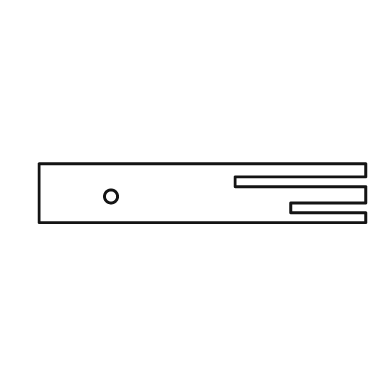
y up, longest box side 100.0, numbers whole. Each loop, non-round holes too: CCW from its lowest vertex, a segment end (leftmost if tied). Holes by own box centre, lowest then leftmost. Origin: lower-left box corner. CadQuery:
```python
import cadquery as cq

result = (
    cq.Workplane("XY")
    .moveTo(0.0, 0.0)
    .lineTo(100.0, 0.0)
    .lineTo(100.0, 3.0)
    .lineTo(77.0, 3.0)
    .lineTo(77.0, 6.0)
    .lineTo(100.0, 6.0)
    .lineTo(100.0, 11.0)
    .lineTo(60.0, 11.0)
    .lineTo(60.0, 14.0)
    .lineTo(100.0, 14.0)
    .lineTo(100.0, 18.0)
    .lineTo(0.0, 18.0)
    .close()
    .moveTo(22.0, 8.0)
    .circle(2.0)
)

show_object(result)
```